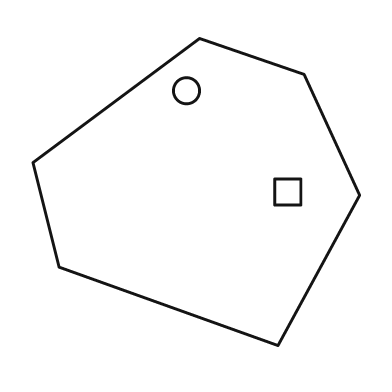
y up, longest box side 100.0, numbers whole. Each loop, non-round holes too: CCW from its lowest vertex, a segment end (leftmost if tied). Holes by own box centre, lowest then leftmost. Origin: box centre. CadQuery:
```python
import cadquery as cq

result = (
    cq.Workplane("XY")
    .moveTo(25.0, -47.0)
    .lineTo(50.0, -1.0)
    .lineTo(33.0, 36.0)
    .lineTo(1.0, 47.0)
    .lineTo(-50.0, 9.0)
    .lineTo(-42.0, -23.0)
    .close()
    .moveTo(24.0, -4.0)
    .lineTo(32.0, -4.0)
    .lineTo(32.0, 4.0)
    .lineTo(24.0, 4.0)
    .close()
    .moveTo(-3.0, 31.0)
    .circle(4.0)
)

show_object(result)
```